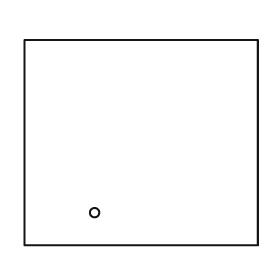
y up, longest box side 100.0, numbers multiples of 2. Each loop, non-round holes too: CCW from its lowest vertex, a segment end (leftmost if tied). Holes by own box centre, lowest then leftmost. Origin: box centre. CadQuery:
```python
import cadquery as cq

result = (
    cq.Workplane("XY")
    .moveTo(-50.0, -44.0)
    .lineTo(50.0, -44.0)
    .lineTo(50.0, 44.0)
    .lineTo(-50.0, 44.0)
    .close()
    .moveTo(-20.0, -30.0)
    .circle(2.0)
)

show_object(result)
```